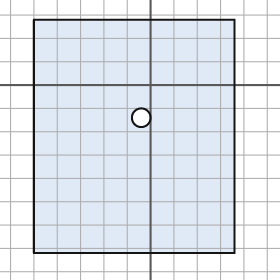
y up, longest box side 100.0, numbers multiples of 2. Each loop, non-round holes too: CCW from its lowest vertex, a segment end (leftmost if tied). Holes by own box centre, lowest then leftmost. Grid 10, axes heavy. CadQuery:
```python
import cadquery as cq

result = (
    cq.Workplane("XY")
    .moveTo(-50.0, -72.0)
    .lineTo(36.0, -72.0)
    .lineTo(36.0, 28.0)
    .lineTo(-50.0, 28.0)
    .close()
    .moveTo(-4.0, -14.0)
    .circle(4.0)
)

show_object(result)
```